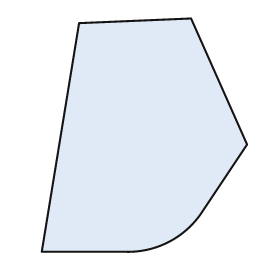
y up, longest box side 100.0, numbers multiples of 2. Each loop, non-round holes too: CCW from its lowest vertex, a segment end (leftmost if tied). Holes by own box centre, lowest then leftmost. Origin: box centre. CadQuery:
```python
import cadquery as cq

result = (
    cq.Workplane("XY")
    .moveTo(-44.0, -50.0)
    .lineTo(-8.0, -50.0)
    .threePointArc((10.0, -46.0), (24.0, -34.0))
    .lineTo(44.0, -4.0)
    .lineTo(20.0, 50.0)
    .lineTo(-28.0, 48.0)
    .close()
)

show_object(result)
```